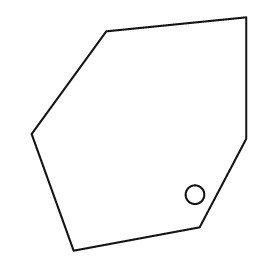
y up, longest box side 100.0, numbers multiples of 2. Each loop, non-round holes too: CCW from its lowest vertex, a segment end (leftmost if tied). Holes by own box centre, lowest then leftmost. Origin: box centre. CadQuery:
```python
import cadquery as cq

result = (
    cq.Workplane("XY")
    .moveTo(-28.0, -50.0)
    .lineTo(26.0, -40.0)
    .lineTo(46.0, -2.0)
    .lineTo(46.0, 50.0)
    .lineTo(-14.0, 44.0)
    .lineTo(-46.0, 0.0)
    .close()
    .moveTo(24.0, -26.0)
    .circle(4.0)
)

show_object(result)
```